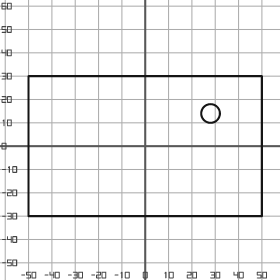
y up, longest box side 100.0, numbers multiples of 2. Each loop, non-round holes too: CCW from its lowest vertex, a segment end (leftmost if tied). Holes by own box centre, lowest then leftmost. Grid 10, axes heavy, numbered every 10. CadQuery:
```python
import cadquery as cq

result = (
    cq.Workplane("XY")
    .moveTo(-50.0, -30.0)
    .lineTo(50.0, -30.0)
    .lineTo(50.0, 30.0)
    .lineTo(-50.0, 30.0)
    .close()
    .moveTo(28.0, 14.0)
    .circle(4.0)
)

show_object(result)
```